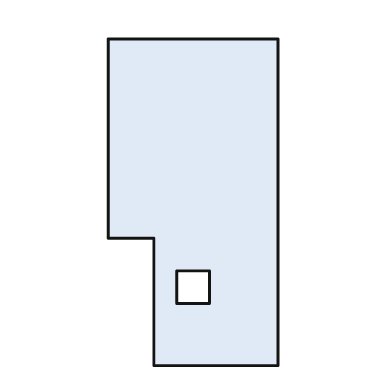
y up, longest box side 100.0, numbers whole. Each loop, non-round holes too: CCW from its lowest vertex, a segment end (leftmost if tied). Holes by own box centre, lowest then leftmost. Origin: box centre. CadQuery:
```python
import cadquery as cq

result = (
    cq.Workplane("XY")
    .moveTo(-12.0, -50.0)
    .lineTo(26.0, -50.0)
    .lineTo(26.0, 50.0)
    .lineTo(-26.0, 50.0)
    .lineTo(-26.0, -11.0)
    .lineTo(-12.0, -11.0)
    .close()
    .moveTo(-5.0, -31.0)
    .lineTo(5.0, -31.0)
    .lineTo(5.0, -21.0)
    .lineTo(-5.0, -21.0)
    .close()
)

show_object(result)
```